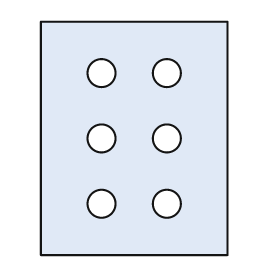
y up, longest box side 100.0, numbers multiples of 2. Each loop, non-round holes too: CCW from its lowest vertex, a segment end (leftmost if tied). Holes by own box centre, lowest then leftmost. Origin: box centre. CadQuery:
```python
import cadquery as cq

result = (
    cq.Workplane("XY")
    .moveTo(-40.0, -50.0)
    .lineTo(40.0, -50.0)
    .lineTo(40.0, 50.0)
    .lineTo(-40.0, 50.0)
    .close()
    .moveTo(-14.0, -28.0)
    .circle(6.0)
    .moveTo(14.0, -28.0)
    .circle(6.0)
    .moveTo(-14.0, 0.0)
    .circle(6.0)
    .moveTo(14.0, 0.0)
    .circle(6.0)
    .moveTo(-14.0, 28.0)
    .circle(6.0)
    .moveTo(14.0, 28.0)
    .circle(6.0)
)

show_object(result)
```